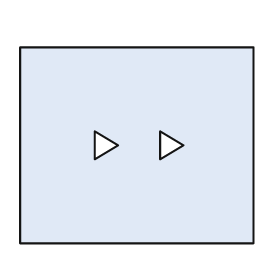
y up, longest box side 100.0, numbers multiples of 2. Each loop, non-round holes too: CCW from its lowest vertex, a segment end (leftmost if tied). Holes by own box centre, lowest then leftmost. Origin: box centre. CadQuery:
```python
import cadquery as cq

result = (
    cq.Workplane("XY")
    .moveTo(-50.0, -42.0)
    .lineTo(50.0, -42.0)
    .lineTo(50.0, 42.0)
    .lineTo(-50.0, 42.0)
    .close()
    .moveTo(-18.0, -6.0)
    .lineTo(-8.0, 0.0)
    .lineTo(-18.0, 6.0)
    .close()
    .moveTo(10.0, -6.0)
    .lineTo(20.0, 0.0)
    .lineTo(10.0, 6.0)
    .close()
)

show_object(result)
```